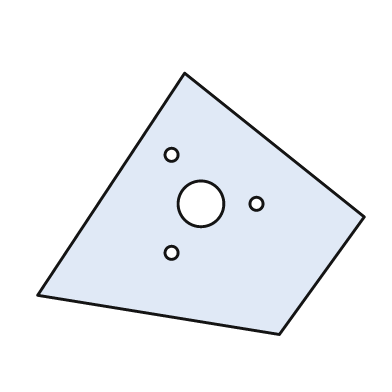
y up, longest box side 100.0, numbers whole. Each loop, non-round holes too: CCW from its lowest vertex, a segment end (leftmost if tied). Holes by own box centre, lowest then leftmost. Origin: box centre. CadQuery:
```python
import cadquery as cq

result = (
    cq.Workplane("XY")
    .moveTo(24.0, -40.0)
    .lineTo(50.0, -4.0)
    .lineTo(-5.0, 40.0)
    .lineTo(-50.0, -28.0)
    .close()
    .moveTo(-9.0, -15.0)
    .circle(2.0)
    .moveTo(0.0, 0.0)
    .circle(7.0)
    .moveTo(17.0, 0.0)
    .circle(2.0)
    .moveTo(-9.0, 15.0)
    .circle(2.0)
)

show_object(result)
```